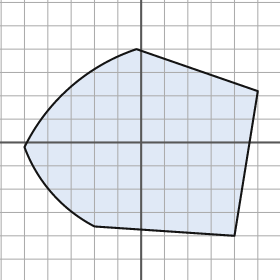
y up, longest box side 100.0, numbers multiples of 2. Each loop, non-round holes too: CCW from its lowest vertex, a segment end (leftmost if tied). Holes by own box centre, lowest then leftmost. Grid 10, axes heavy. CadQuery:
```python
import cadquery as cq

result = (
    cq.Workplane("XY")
    .moveTo(40.0, -40.0)
    .lineTo(50.0, 22.0)
    .lineTo(-2.0, 40.0)
    .threePointArc((-30.0, 24.0), (-50.0, -2.0))
    .threePointArc((-38.0, -22.0), (-20.0, -36.0))
    .close()
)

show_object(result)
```